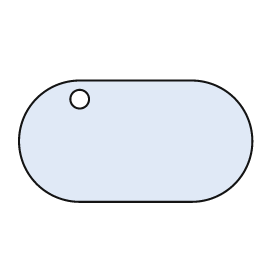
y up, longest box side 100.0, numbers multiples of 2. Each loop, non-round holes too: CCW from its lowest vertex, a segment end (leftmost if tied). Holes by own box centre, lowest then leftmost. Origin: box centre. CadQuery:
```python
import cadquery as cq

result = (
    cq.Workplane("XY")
    .moveTo(-24.0, -26.0)
    .lineTo(24.0, -26.0)
    .threePointArc((50.0, 0.0), (24.0, 26.0))
    .lineTo(-24.0, 26.0)
    .threePointArc((-50.0, 0.0), (-24.0, -26.0))
    .close()
    .moveTo(-24.0, 18.0)
    .circle(4.0)
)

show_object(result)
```